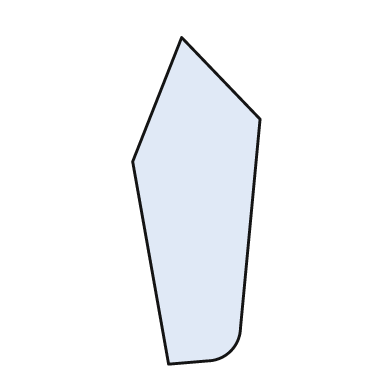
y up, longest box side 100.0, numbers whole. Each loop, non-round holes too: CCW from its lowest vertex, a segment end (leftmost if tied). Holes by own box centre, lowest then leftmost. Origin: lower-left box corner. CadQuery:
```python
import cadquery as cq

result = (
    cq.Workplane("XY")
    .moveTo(11.0, 0.0)
    .lineTo(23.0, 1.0)
    .threePointArc((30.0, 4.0), (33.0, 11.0))
    .lineTo(39.0, 75.0)
    .lineTo(15.0, 100.0)
    .lineTo(0.0, 62.0)
    .close()
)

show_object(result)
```